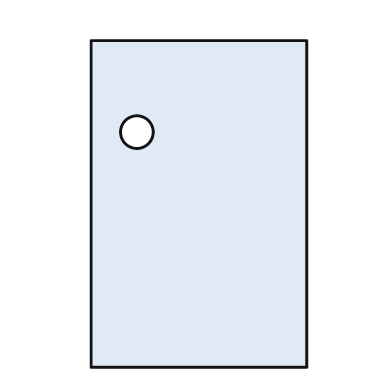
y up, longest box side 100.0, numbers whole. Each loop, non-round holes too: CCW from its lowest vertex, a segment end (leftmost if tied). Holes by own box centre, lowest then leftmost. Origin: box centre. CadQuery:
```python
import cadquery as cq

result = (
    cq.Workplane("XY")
    .moveTo(-33.0, -50.0)
    .lineTo(33.0, -50.0)
    .lineTo(33.0, 50.0)
    .lineTo(-33.0, 50.0)
    .close()
    .moveTo(-19.0, 22.0)
    .circle(5.0)
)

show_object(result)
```